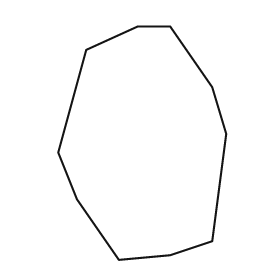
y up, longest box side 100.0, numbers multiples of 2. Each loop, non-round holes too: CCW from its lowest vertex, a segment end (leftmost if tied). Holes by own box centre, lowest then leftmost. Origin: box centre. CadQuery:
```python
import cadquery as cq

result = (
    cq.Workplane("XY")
    .moveTo(-10.0, -50.0)
    .lineTo(12.0, -48.0)
    .lineTo(30.0, -42.0)
    .lineTo(36.0, 4.0)
    .lineTo(30.0, 24.0)
    .lineTo(12.0, 50.0)
    .lineTo(-2.0, 50.0)
    .lineTo(-24.0, 40.0)
    .lineTo(-36.0, -4.0)
    .lineTo(-28.0, -24.0)
    .close()
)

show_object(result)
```